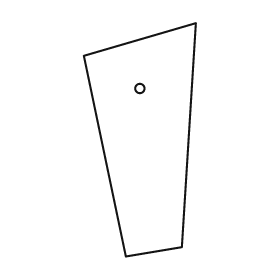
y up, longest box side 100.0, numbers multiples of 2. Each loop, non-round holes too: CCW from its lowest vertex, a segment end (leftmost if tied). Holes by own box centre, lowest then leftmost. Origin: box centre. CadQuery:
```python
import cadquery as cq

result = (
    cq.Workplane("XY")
    .moveTo(-6.0, -50.0)
    .lineTo(18.0, -46.0)
    .lineTo(24.0, 50.0)
    .lineTo(-24.0, 36.0)
    .close()
    .moveTo(0.0, 22.0)
    .circle(2.0)
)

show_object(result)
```